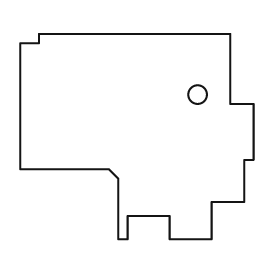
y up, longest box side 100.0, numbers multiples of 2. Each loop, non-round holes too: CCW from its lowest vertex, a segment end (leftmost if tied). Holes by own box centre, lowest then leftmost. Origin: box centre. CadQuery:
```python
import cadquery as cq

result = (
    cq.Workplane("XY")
    .moveTo(-8.0, -44.0)
    .lineTo(-4.0, -44.0)
    .lineTo(-4.0, -34.0)
    .lineTo(14.0, -34.0)
    .lineTo(14.0, -44.0)
    .lineTo(32.0, -44.0)
    .lineTo(32.0, -28.0)
    .lineTo(46.0, -28.0)
    .lineTo(46.0, -10.0)
    .lineTo(50.0, -10.0)
    .lineTo(50.0, 14.0)
    .lineTo(40.0, 14.0)
    .lineTo(40.0, 44.0)
    .lineTo(-42.0, 44.0)
    .lineTo(-42.0, 40.0)
    .lineTo(-50.0, 40.0)
    .lineTo(-50.0, -14.0)
    .lineTo(-12.0, -14.0)
    .lineTo(-8.0, -18.0)
    .close()
    .moveTo(26.0, 18.0)
    .circle(4.0)
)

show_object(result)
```